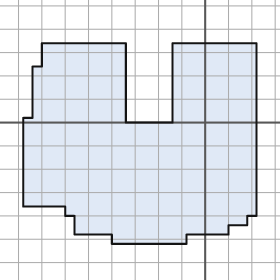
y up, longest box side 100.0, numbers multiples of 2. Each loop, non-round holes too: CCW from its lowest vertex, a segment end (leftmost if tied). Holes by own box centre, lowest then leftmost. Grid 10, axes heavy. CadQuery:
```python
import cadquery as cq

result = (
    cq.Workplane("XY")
    .moveTo(-40.0, -52.0)
    .lineTo(-8.0, -52.0)
    .lineTo(-8.0, -48.0)
    .lineTo(10.0, -48.0)
    .lineTo(10.0, -44.0)
    .lineTo(18.0, -44.0)
    .lineTo(18.0, -40.0)
    .lineTo(22.0, -40.0)
    .lineTo(22.0, 34.0)
    .lineTo(-14.0, 34.0)
    .lineTo(-14.0, 0.0)
    .lineTo(-34.0, 0.0)
    .lineTo(-34.0, 34.0)
    .lineTo(-70.0, 34.0)
    .lineTo(-70.0, 24.0)
    .lineTo(-74.0, 24.0)
    .lineTo(-74.0, 2.0)
    .lineTo(-78.0, 2.0)
    .lineTo(-78.0, -36.0)
    .lineTo(-60.0, -36.0)
    .lineTo(-60.0, -40.0)
    .lineTo(-56.0, -40.0)
    .lineTo(-56.0, -48.0)
    .lineTo(-40.0, -48.0)
    .close()
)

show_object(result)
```